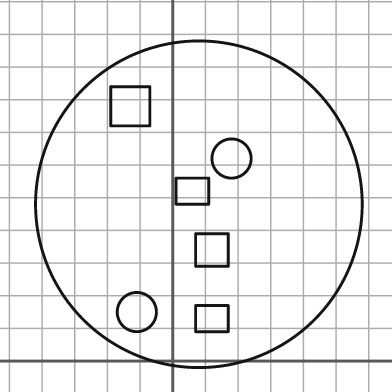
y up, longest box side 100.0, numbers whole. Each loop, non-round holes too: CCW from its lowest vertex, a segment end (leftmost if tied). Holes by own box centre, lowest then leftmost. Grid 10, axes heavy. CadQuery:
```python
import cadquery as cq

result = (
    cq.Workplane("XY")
    .moveTo(8.0, 48.0)
    .circle(50.0)
    .moveTo(7.0, 9.0)
    .lineTo(17.0, 9.0)
    .lineTo(17.0, 17.0)
    .lineTo(7.0, 17.0)
    .close()
    .moveTo(-11.0, 15.0)
    .circle(6.0)
    .moveTo(7.0, 29.0)
    .lineTo(17.0, 29.0)
    .lineTo(17.0, 39.0)
    .lineTo(7.0, 39.0)
    .close()
    .moveTo(1.0, 48.0)
    .lineTo(11.0, 48.0)
    .lineTo(11.0, 56.0)
    .lineTo(1.0, 56.0)
    .close()
    .moveTo(18.0, 62.0)
    .circle(6.0)
    .moveTo(-19.0, 72.0)
    .lineTo(-7.0, 72.0)
    .lineTo(-7.0, 84.0)
    .lineTo(-19.0, 84.0)
    .close()
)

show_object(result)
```